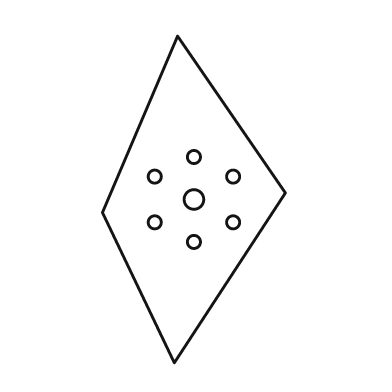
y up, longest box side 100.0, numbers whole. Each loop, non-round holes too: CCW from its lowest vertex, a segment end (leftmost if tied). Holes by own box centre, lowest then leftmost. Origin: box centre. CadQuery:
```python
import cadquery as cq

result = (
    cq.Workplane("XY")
    .moveTo(-6.0, -50.0)
    .lineTo(28.0, 2.0)
    .lineTo(-5.0, 50.0)
    .lineTo(-28.0, -4.0)
    .close()
    .moveTo(0.0, -13.0)
    .circle(2.0)
    .moveTo(-12.0, -7.0)
    .circle(2.0)
    .moveTo(12.0, -7.0)
    .circle(2.0)
    .moveTo(0.0, 0.0)
    .circle(3.0)
    .moveTo(-12.0, 7.0)
    .circle(2.0)
    .moveTo(12.0, 7.0)
    .circle(2.0)
    .moveTo(0.0, 13.0)
    .circle(2.0)
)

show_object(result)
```